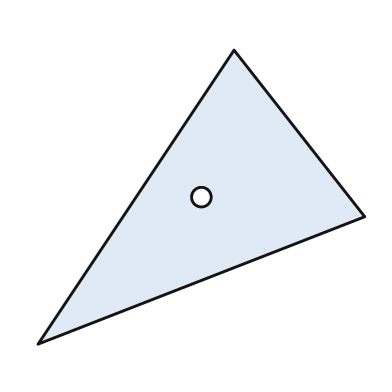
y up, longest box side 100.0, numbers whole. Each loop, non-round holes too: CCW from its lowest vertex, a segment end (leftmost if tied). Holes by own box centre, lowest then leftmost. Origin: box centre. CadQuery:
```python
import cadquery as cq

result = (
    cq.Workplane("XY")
    .moveTo(-50.0, -45.0)
    .lineTo(50.0, -6.0)
    .lineTo(10.0, 45.0)
    .close()
    .moveTo(0.0, 0.0)
    .circle(3.0)
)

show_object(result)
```